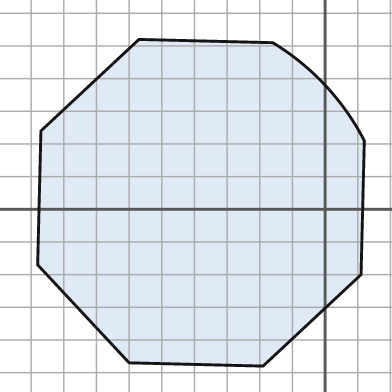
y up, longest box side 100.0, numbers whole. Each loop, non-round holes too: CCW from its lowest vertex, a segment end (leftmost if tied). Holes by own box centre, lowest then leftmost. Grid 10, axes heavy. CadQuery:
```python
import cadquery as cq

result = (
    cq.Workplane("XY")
    .moveTo(-19.0, -48.0)
    .lineTo(11.0, -20.0)
    .lineTo(12.0, 21.0)
    .threePointArc((0.0, 38.0), (-16.0, 51.0))
    .lineTo(-57.0, 52.0)
    .lineTo(-87.0, 24.0)
    .lineTo(-88.0, -17.0)
    .lineTo(-60.0, -47.0)
    .close()
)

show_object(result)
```